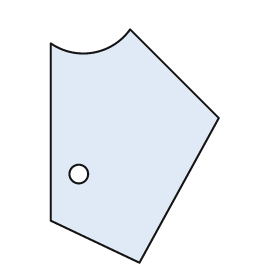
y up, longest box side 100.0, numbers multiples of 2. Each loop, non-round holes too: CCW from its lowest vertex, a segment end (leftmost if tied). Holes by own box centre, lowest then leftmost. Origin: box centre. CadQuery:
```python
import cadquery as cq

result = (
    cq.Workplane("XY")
    .moveTo(2.0, -50.0)
    .lineTo(36.0, 12.0)
    .lineTo(-2.0, 50.0)
    .threePointArc((-18.0, 40.0), (-36.0, 44.0))
    .lineTo(-36.0, -32.0)
    .close()
    .moveTo(-24.0, -12.0)
    .circle(4.0)
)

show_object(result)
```